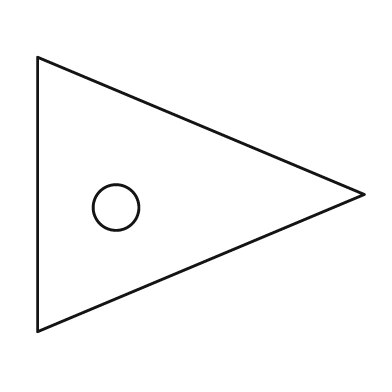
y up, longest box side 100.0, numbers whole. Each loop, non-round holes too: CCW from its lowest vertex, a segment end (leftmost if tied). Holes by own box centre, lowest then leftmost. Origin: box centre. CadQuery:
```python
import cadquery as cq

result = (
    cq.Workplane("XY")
    .moveTo(-50.0, -42.0)
    .lineTo(50.0, 0.0)
    .lineTo(-50.0, 42.0)
    .close()
    .moveTo(-26.0, -4.0)
    .circle(7.0)
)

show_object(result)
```